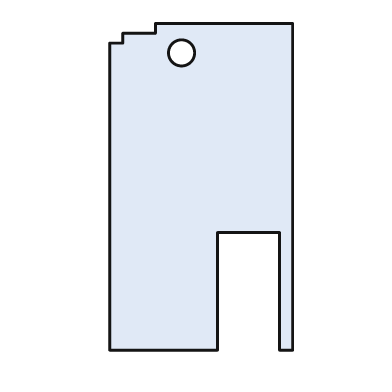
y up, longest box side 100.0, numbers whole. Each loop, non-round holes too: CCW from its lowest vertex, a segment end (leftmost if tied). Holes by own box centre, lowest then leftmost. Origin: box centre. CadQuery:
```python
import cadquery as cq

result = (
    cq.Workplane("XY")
    .moveTo(-28.0, -50.0)
    .lineTo(5.0, -50.0)
    .lineTo(5.0, -14.0)
    .lineTo(24.0, -14.0)
    .lineTo(24.0, -50.0)
    .lineTo(28.0, -50.0)
    .lineTo(28.0, 50.0)
    .lineTo(-14.0, 50.0)
    .lineTo(-14.0, 47.0)
    .lineTo(-24.0, 47.0)
    .lineTo(-24.0, 44.0)
    .lineTo(-28.0, 44.0)
    .close()
    .moveTo(-6.0, 41.0)
    .circle(4.0)
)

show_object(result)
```